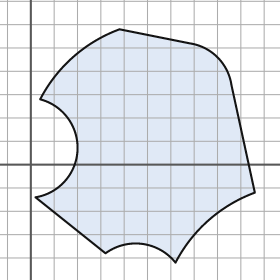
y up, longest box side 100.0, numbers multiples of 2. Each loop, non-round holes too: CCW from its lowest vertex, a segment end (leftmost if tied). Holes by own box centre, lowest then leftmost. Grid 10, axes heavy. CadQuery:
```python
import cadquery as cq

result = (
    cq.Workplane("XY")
    .moveTo(62.0, -42.0)
    .threePointArc((76.0, -24.0), (96.0, -12.0))
    .lineTo(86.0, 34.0)
    .threePointArc((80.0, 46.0), (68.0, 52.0))
    .lineTo(38.0, 58.0)
    .threePointArc((18.0, 46.0), (4.0, 28.0))
    .threePointArc((20.0, 6.0), (2.0, -14.0))
    .lineTo(32.0, -38.0)
    .threePointArc((48.0, -34.0), (62.0, -42.0))
    .close()
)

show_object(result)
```